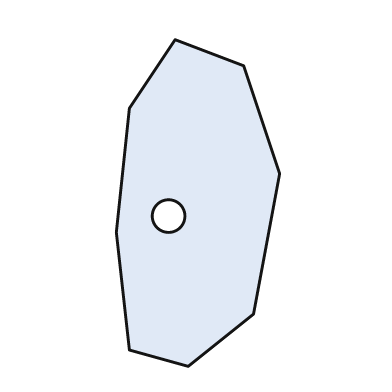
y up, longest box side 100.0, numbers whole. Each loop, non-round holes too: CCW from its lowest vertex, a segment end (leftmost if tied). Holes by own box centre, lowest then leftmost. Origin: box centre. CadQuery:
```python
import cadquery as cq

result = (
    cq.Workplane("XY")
    .moveTo(-3.0, -50.0)
    .lineTo(17.0, -34.0)
    .lineTo(25.0, 9.0)
    .lineTo(14.0, 42.0)
    .lineTo(-7.0, 50.0)
    .lineTo(-21.0, 29.0)
    .lineTo(-25.0, -9.0)
    .lineTo(-21.0, -45.0)
    .close()
    .moveTo(-9.0, -4.0)
    .circle(5.0)
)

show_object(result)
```